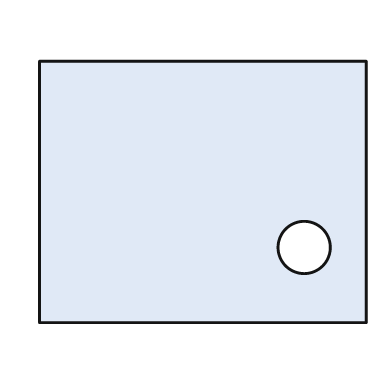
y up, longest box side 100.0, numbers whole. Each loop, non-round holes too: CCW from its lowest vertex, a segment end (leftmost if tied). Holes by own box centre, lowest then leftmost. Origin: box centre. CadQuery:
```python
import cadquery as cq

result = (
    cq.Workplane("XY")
    .moveTo(-50.0, -40.0)
    .lineTo(50.0, -40.0)
    .lineTo(50.0, 40.0)
    .lineTo(-50.0, 40.0)
    .close()
    .moveTo(31.0, -17.0)
    .circle(8.0)
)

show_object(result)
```